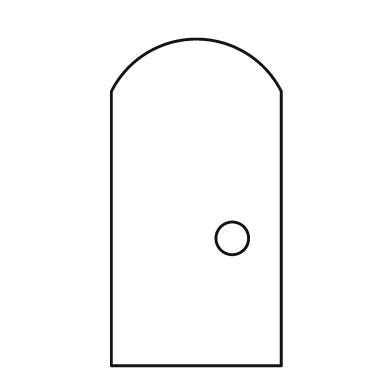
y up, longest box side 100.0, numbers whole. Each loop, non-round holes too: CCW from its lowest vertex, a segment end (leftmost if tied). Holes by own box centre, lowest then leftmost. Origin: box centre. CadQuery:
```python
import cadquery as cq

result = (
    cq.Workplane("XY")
    .moveTo(-26.0, -50.0)
    .lineTo(26.0, -50.0)
    .lineTo(26.0, 34.0)
    .threePointArc((0.0, 50.0), (-26.0, 34.0))
    .close()
    .moveTo(11.0, -11.0)
    .circle(5.0)
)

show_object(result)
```